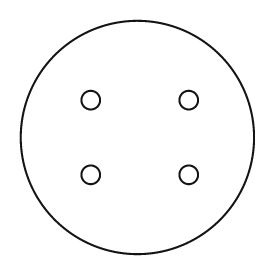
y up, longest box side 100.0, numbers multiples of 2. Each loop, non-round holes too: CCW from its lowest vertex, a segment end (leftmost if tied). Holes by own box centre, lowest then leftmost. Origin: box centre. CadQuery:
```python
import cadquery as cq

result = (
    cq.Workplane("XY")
    .moveTo(0.0, 0.0)
    .circle(50.0)
    .moveTo(-20.0, -16.0)
    .circle(4.0)
    .moveTo(22.0, -16.0)
    .circle(4.0)
    .moveTo(-20.0, 16.0)
    .circle(4.0)
    .moveTo(22.0, 16.0)
    .circle(4.0)
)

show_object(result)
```